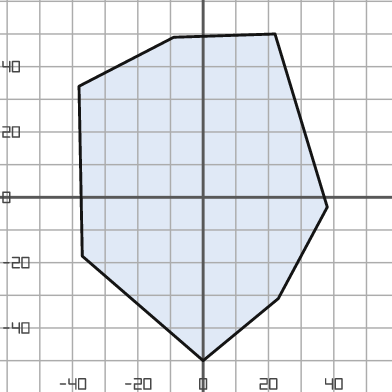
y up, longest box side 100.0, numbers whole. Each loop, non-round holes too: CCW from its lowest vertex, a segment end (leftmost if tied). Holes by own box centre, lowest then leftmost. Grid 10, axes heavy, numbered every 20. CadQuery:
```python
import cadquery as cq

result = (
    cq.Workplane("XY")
    .moveTo(0.0, -50.0)
    .lineTo(23.0, -31.0)
    .lineTo(38.0, -3.0)
    .lineTo(22.0, 50.0)
    .lineTo(-9.0, 49.0)
    .lineTo(-38.0, 34.0)
    .lineTo(-37.0, -18.0)
    .close()
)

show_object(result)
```